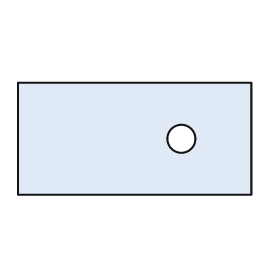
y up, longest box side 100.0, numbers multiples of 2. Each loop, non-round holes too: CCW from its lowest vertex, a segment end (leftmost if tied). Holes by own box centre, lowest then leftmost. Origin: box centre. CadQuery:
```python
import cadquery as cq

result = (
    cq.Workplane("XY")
    .moveTo(-50.0, -24.0)
    .lineTo(50.0, -24.0)
    .lineTo(50.0, 24.0)
    .lineTo(-50.0, 24.0)
    .close()
    .moveTo(20.0, 0.0)
    .circle(6.0)
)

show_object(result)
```